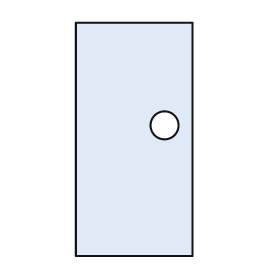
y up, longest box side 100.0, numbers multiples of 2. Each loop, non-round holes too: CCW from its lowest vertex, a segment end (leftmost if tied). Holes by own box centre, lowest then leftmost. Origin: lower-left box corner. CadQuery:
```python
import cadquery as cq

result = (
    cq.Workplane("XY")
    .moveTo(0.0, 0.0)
    .lineTo(50.0, 0.0)
    .lineTo(50.0, 100.0)
    .lineTo(0.0, 100.0)
    .close()
    .moveTo(38.0, 56.0)
    .circle(6.0)
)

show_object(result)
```